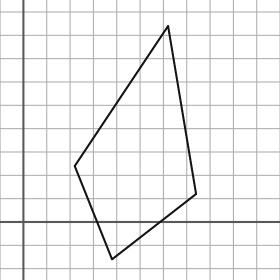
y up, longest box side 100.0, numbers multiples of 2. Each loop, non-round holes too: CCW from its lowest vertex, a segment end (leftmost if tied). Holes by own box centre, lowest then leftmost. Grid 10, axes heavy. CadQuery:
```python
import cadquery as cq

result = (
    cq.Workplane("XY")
    .moveTo(38.0, -16.0)
    .lineTo(74.0, 12.0)
    .lineTo(62.0, 84.0)
    .lineTo(22.0, 24.0)
    .close()
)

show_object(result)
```